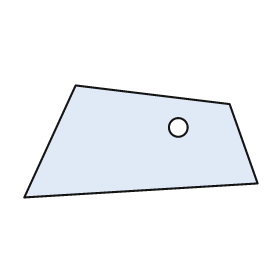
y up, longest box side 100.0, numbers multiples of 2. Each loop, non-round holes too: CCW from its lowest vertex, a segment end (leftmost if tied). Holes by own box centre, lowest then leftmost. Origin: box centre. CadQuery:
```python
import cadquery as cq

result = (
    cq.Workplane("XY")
    .moveTo(-50.0, -24.0)
    .lineTo(50.0, -18.0)
    .lineTo(38.0, 16.0)
    .lineTo(-28.0, 24.0)
    .close()
    .moveTo(16.0, 6.0)
    .circle(4.0)
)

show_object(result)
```